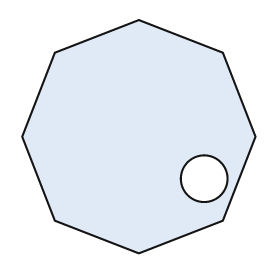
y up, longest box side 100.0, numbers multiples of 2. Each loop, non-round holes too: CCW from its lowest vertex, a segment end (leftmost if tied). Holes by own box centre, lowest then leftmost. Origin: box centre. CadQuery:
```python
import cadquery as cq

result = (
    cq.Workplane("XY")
    .moveTo(0.0, -50.0)
    .lineTo(36.0, -36.0)
    .lineTo(50.0, 0.0)
    .lineTo(36.0, 36.0)
    .lineTo(0.0, 50.0)
    .lineTo(-36.0, 36.0)
    .lineTo(-50.0, 0.0)
    .lineTo(-36.0, -36.0)
    .close()
    .moveTo(28.0, -18.0)
    .circle(10.0)
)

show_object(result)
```